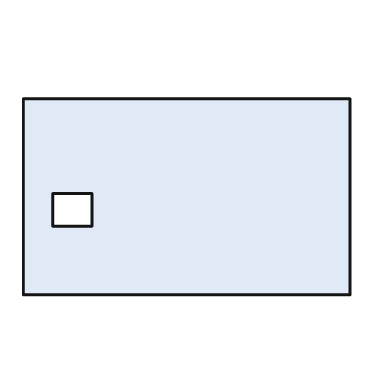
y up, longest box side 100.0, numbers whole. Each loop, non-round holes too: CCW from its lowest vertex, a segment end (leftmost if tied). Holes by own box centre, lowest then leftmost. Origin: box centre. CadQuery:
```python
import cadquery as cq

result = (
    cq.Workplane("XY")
    .moveTo(-50.0, -30.0)
    .lineTo(50.0, -30.0)
    .lineTo(50.0, 30.0)
    .lineTo(-50.0, 30.0)
    .close()
    .moveTo(-41.0, -9.0)
    .lineTo(-29.0, -9.0)
    .lineTo(-29.0, 1.0)
    .lineTo(-41.0, 1.0)
    .close()
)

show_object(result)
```